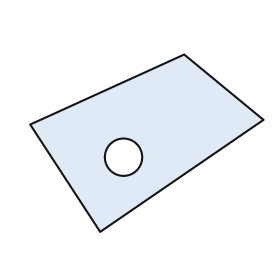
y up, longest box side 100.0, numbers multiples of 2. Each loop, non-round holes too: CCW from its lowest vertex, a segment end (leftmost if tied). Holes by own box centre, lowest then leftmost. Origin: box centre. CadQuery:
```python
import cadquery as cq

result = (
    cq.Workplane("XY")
    .moveTo(-20.0, -38.0)
    .lineTo(50.0, 10.0)
    .lineTo(16.0, 38.0)
    .lineTo(-50.0, 8.0)
    .close()
    .moveTo(-10.0, -6.0)
    .circle(8.0)
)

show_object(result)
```